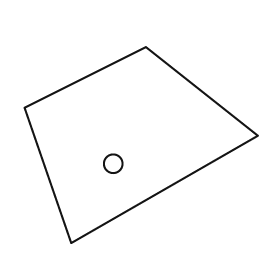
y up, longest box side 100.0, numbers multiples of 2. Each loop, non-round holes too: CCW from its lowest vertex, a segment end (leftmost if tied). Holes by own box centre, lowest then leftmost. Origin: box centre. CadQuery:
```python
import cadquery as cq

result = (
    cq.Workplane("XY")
    .moveTo(-30.0, -42.0)
    .lineTo(50.0, 4.0)
    .lineTo(2.0, 42.0)
    .lineTo(-50.0, 16.0)
    .close()
    .moveTo(-12.0, -8.0)
    .circle(4.0)
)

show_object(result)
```